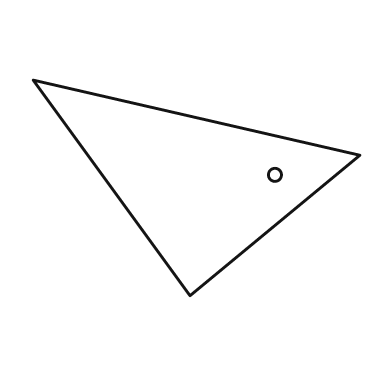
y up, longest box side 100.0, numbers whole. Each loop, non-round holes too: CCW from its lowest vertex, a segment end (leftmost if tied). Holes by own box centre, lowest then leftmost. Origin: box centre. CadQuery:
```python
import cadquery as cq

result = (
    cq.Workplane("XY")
    .moveTo(-2.0, -33.0)
    .lineTo(50.0, 10.0)
    .lineTo(-50.0, 33.0)
    .close()
    .moveTo(24.0, 4.0)
    .circle(2.0)
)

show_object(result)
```